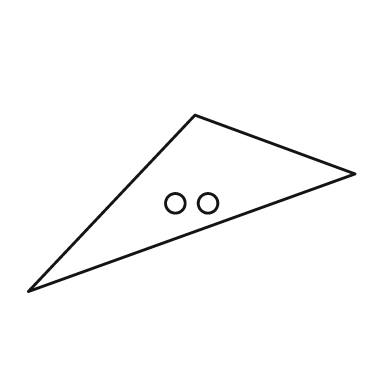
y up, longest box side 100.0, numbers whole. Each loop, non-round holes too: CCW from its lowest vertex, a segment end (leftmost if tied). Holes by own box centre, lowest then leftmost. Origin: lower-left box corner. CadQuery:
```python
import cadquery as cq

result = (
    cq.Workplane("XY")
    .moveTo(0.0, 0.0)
    .lineTo(100.0, 36.0)
    .lineTo(51.0, 54.0)
    .close()
    .moveTo(45.0, 27.0)
    .circle(3.0)
    .moveTo(55.0, 27.0)
    .circle(3.0)
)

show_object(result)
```